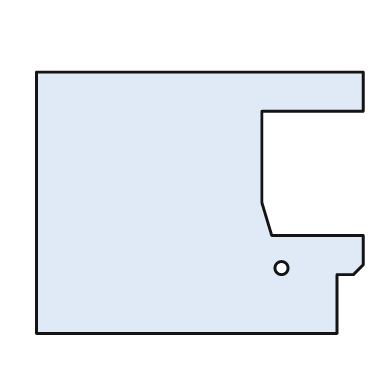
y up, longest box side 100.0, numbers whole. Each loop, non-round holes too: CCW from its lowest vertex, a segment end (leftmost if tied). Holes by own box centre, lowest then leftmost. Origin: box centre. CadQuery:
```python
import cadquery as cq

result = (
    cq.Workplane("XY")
    .moveTo(-50.0, -40.0)
    .lineTo(42.0, -40.0)
    .lineTo(42.0, -22.0)
    .lineTo(47.0, -22.0)
    .lineTo(50.0, -19.0)
    .lineTo(50.0, -10.0)
    .lineTo(22.0, -10.0)
    .lineTo(19.0, 0.0)
    .lineTo(19.0, 28.0)
    .lineTo(50.0, 28.0)
    .lineTo(50.0, 40.0)
    .lineTo(-50.0, 40.0)
    .close()
    .moveTo(25.0, -20.0)
    .circle(2.0)
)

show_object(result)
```